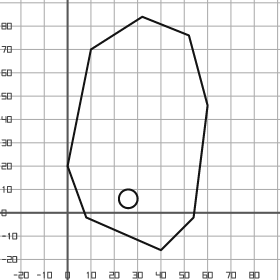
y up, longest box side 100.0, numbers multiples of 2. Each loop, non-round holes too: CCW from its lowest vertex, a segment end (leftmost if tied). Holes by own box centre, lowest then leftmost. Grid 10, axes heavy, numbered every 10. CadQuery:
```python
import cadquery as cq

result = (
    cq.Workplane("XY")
    .moveTo(40.0, -16.0)
    .lineTo(54.0, -2.0)
    .lineTo(60.0, 46.0)
    .lineTo(52.0, 76.0)
    .lineTo(32.0, 84.0)
    .lineTo(10.0, 70.0)
    .lineTo(0.0, 20.0)
    .lineTo(8.0, -2.0)
    .close()
    .moveTo(26.0, 6.0)
    .circle(4.0)
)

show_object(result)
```